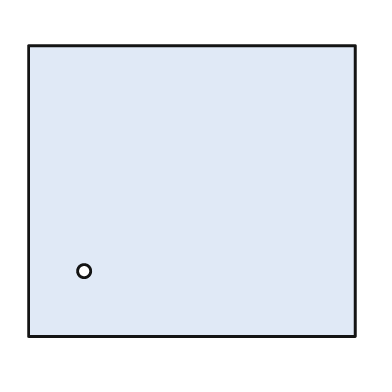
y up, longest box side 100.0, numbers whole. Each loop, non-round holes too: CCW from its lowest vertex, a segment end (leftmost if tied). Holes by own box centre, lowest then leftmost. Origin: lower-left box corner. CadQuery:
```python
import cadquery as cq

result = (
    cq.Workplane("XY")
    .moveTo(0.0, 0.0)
    .lineTo(100.0, 0.0)
    .lineTo(100.0, 89.0)
    .lineTo(0.0, 89.0)
    .close()
    .moveTo(17.0, 20.0)
    .circle(2.0)
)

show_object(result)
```